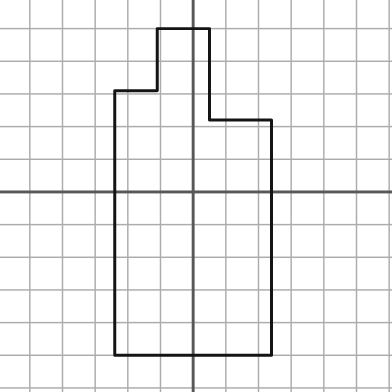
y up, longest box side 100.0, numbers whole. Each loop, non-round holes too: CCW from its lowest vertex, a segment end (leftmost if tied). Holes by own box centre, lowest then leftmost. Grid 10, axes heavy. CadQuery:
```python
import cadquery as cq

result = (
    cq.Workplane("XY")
    .moveTo(-24.0, -50.0)
    .lineTo(24.0, -50.0)
    .lineTo(24.0, 22.0)
    .lineTo(5.0, 22.0)
    .lineTo(5.0, 50.0)
    .lineTo(-11.0, 50.0)
    .lineTo(-11.0, 31.0)
    .lineTo(-24.0, 31.0)
    .close()
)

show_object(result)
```